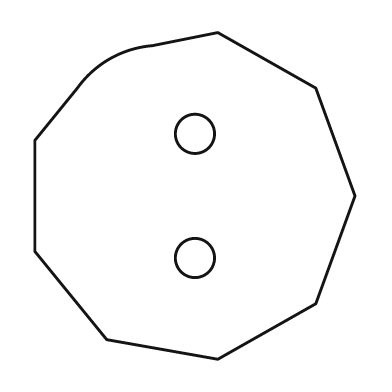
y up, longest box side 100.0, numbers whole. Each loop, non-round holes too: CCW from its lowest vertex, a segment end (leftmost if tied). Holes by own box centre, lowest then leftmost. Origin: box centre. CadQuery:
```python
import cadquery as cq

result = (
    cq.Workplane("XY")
    .moveTo(7.0, -50.0)
    .lineTo(37.0, -33.0)
    .lineTo(49.0, 0.0)
    .lineTo(37.0, 33.0)
    .lineTo(7.0, 50.0)
    .lineTo(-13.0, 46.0)
    .threePointArc((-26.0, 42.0), (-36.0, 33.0))
    .lineTo(-49.0, 17.0)
    .lineTo(-49.0, -17.0)
    .lineTo(-27.0, -44.0)
    .close()
    .moveTo(0.0, -19.0)
    .circle(6.0)
    .moveTo(0.0, 19.0)
    .circle(6.0)
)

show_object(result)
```